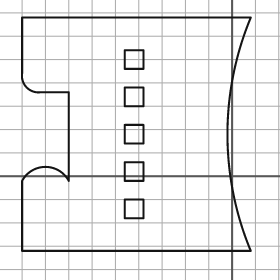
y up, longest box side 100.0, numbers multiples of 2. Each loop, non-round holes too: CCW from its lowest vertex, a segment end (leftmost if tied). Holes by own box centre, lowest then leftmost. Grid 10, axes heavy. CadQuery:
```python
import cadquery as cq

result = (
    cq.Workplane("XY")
    .moveTo(-90.0, -32.0)
    .lineTo(8.0, -32.0)
    .threePointArc((-2.0, 18.0), (8.0, 68.0))
    .lineTo(-90.0, 68.0)
    .lineTo(-90.0, 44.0)
    .threePointArc((-88.0, 38.0), (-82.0, 36.0))
    .lineTo(-70.0, 36.0)
    .lineTo(-70.0, -2.0)
    .threePointArc((-80.0, 4.0), (-90.0, -2.0))
    .close()
    .moveTo(-46.0, -18.0)
    .lineTo(-38.0, -18.0)
    .lineTo(-38.0, -10.0)
    .lineTo(-46.0, -10.0)
    .close()
    .moveTo(-46.0, -2.0)
    .lineTo(-38.0, -2.0)
    .lineTo(-38.0, 6.0)
    .lineTo(-46.0, 6.0)
    .close()
    .moveTo(-46.0, 14.0)
    .lineTo(-38.0, 14.0)
    .lineTo(-38.0, 22.0)
    .lineTo(-46.0, 22.0)
    .close()
    .moveTo(-46.0, 30.0)
    .lineTo(-38.0, 30.0)
    .lineTo(-38.0, 38.0)
    .lineTo(-46.0, 38.0)
    .close()
    .moveTo(-46.0, 46.0)
    .lineTo(-38.0, 46.0)
    .lineTo(-38.0, 54.0)
    .lineTo(-46.0, 54.0)
    .close()
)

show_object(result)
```